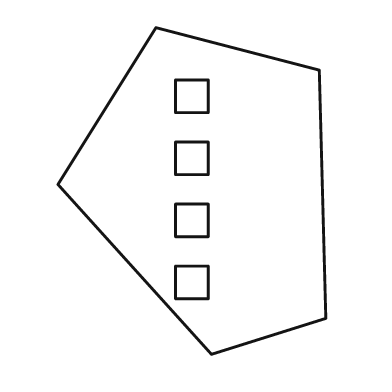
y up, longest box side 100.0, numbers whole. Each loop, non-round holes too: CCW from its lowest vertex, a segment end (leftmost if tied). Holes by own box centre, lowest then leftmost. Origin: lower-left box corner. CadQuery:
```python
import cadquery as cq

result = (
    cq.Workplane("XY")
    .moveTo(47.0, 0.0)
    .lineTo(82.0, 11.0)
    .lineTo(80.0, 87.0)
    .lineTo(30.0, 100.0)
    .lineTo(0.0, 52.0)
    .close()
    .moveTo(36.0, 17.0)
    .lineTo(46.0, 17.0)
    .lineTo(46.0, 27.0)
    .lineTo(36.0, 27.0)
    .close()
    .moveTo(36.0, 36.0)
    .lineTo(46.0, 36.0)
    .lineTo(46.0, 46.0)
    .lineTo(36.0, 46.0)
    .close()
    .moveTo(36.0, 55.0)
    .lineTo(46.0, 55.0)
    .lineTo(46.0, 65.0)
    .lineTo(36.0, 65.0)
    .close()
    .moveTo(36.0, 74.0)
    .lineTo(46.0, 74.0)
    .lineTo(46.0, 84.0)
    .lineTo(36.0, 84.0)
    .close()
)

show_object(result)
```